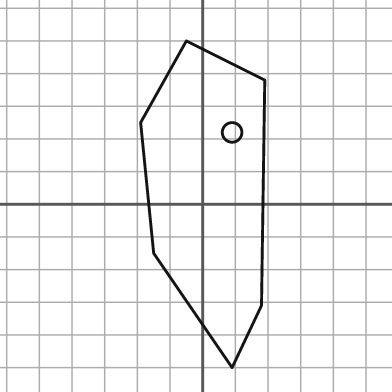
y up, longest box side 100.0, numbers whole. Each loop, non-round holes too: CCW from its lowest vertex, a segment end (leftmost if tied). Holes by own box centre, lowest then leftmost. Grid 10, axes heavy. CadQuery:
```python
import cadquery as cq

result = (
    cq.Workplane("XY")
    .moveTo(9.0, -50.0)
    .lineTo(18.0, -31.0)
    .lineTo(19.0, 38.0)
    .lineTo(-5.0, 50.0)
    .lineTo(-19.0, 25.0)
    .lineTo(-15.0, -15.0)
    .close()
    .moveTo(9.0, 22.0)
    .circle(3.0)
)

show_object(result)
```